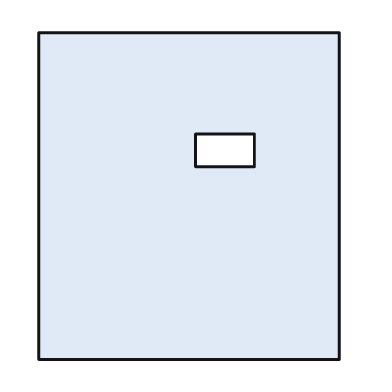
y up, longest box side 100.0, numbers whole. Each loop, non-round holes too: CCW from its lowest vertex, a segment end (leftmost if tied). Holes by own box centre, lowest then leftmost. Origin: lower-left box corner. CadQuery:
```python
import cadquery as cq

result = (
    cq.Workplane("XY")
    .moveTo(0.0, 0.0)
    .lineTo(92.0, 0.0)
    .lineTo(92.0, 100.0)
    .lineTo(0.0, 100.0)
    .close()
    .moveTo(48.0, 59.0)
    .lineTo(66.0, 59.0)
    .lineTo(66.0, 69.0)
    .lineTo(48.0, 69.0)
    .close()
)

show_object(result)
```